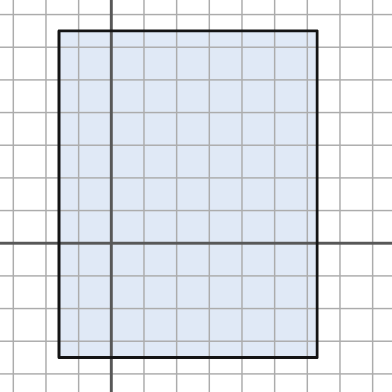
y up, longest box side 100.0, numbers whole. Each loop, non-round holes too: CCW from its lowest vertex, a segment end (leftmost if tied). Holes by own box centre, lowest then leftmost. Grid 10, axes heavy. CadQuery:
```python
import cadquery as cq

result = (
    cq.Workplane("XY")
    .moveTo(-16.0, -35.0)
    .lineTo(63.0, -35.0)
    .lineTo(63.0, 65.0)
    .lineTo(-16.0, 65.0)
    .close()
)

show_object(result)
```